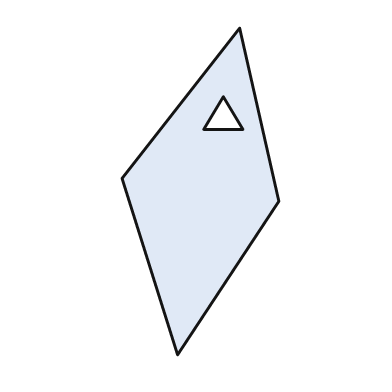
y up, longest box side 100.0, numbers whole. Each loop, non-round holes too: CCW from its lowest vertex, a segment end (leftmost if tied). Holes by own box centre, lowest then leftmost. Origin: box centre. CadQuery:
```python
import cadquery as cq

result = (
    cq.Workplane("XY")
    .moveTo(-7.0, -50.0)
    .lineTo(24.0, -3.0)
    .lineTo(12.0, 50.0)
    .lineTo(-24.0, 4.0)
    .close()
    .moveTo(1.0, 19.0)
    .lineTo(13.0, 19.0)
    .lineTo(7.0, 29.0)
    .close()
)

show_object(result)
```